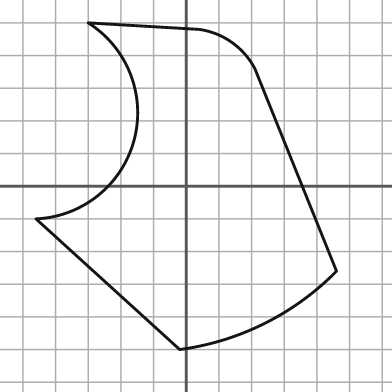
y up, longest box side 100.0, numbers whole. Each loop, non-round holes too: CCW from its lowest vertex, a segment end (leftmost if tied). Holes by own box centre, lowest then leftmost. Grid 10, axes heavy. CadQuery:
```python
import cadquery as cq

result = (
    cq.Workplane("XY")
    .moveTo(-2.0, -50.0)
    .threePointArc((24.0, -42.0), (46.0, -26.0))
    .lineTo(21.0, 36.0)
    .threePointArc((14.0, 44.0), (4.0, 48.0))
    .lineTo(-30.0, 50.0)
    .threePointArc((-16.0, 14.0), (-46.0, -10.0))
    .close()
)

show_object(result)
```